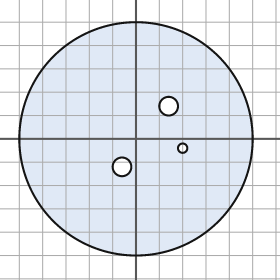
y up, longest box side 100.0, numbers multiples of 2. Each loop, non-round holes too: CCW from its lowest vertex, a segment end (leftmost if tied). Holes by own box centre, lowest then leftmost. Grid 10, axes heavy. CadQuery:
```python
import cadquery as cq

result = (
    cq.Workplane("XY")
    .moveTo(0.0, 0.0)
    .circle(50.0)
    .moveTo(-6.0, -12.0)
    .circle(4.0)
    .moveTo(20.0, -4.0)
    .circle(2.0)
    .moveTo(14.0, 14.0)
    .circle(4.0)
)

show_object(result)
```